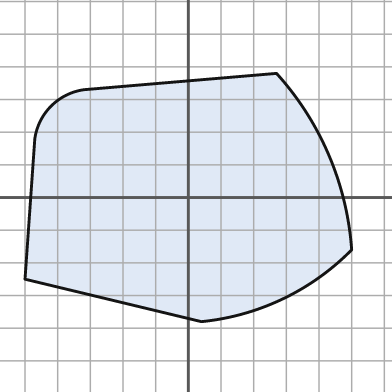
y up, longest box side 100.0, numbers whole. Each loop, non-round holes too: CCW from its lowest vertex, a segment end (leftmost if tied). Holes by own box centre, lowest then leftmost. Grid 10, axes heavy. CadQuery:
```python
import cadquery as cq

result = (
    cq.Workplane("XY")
    .moveTo(4.0, -38.0)
    .threePointArc((29.0, -31.0), (50.0, -16.0))
    .threePointArc((43.0, 13.0), (27.0, 38.0))
    .lineTo(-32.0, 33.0)
    .threePointArc((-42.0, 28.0), (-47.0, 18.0))
    .lineTo(-50.0, -25.0)
    .close()
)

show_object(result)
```